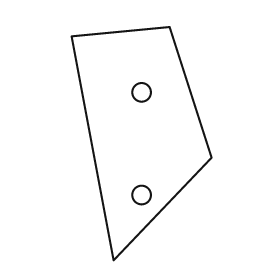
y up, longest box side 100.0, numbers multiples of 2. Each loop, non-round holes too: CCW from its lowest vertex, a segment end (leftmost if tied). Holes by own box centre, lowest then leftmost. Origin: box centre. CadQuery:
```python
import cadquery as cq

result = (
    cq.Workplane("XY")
    .moveTo(-12.0, -50.0)
    .lineTo(30.0, -6.0)
    .lineTo(12.0, 50.0)
    .lineTo(-30.0, 46.0)
    .close()
    .moveTo(0.0, -22.0)
    .circle(4.0)
    .moveTo(0.0, 22.0)
    .circle(4.0)
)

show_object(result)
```